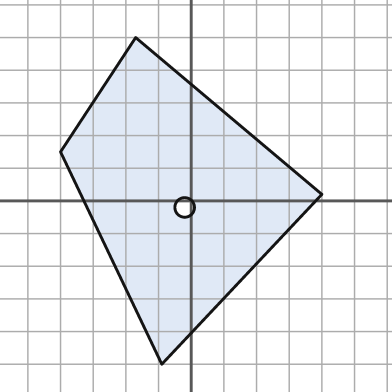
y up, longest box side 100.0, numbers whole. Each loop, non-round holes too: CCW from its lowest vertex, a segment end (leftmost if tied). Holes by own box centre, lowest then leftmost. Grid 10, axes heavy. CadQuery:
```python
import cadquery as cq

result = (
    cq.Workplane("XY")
    .moveTo(-9.0, -50.0)
    .lineTo(40.0, 2.0)
    .lineTo(-17.0, 50.0)
    .lineTo(-40.0, 15.0)
    .close()
    .moveTo(-2.0, -2.0)
    .circle(3.0)
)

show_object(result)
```